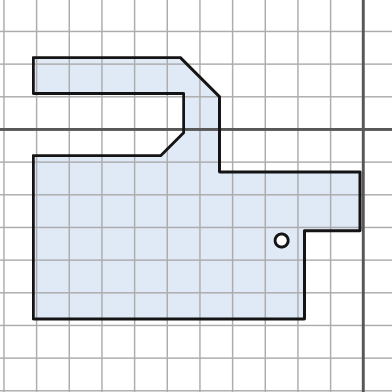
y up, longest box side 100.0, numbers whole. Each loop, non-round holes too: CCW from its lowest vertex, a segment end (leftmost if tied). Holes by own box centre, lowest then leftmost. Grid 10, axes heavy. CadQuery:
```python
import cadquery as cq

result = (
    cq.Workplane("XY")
    .moveTo(-101.0, -58.0)
    .lineTo(-18.0, -58.0)
    .lineTo(-18.0, -31.0)
    .lineTo(-1.0, -31.0)
    .lineTo(-1.0, -13.0)
    .lineTo(-44.0, -13.0)
    .lineTo(-44.0, 10.0)
    .lineTo(-56.0, 22.0)
    .lineTo(-101.0, 22.0)
    .lineTo(-101.0, 11.0)
    .lineTo(-55.0, 11.0)
    .lineTo(-55.0, -1.0)
    .lineTo(-62.0, -8.0)
    .lineTo(-101.0, -8.0)
    .close()
    .moveTo(-25.0, -34.0)
    .circle(2.0)
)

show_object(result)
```